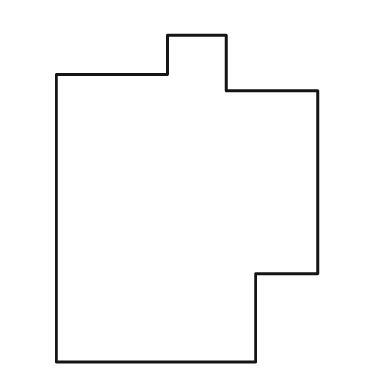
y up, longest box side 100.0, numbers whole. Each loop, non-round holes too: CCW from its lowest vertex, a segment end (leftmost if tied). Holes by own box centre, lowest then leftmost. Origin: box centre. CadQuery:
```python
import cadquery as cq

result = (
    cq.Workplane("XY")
    .moveTo(-40.0, -50.0)
    .lineTo(21.0, -50.0)
    .lineTo(21.0, -23.0)
    .lineTo(40.0, -23.0)
    .lineTo(40.0, 33.0)
    .lineTo(12.0, 33.0)
    .lineTo(12.0, 50.0)
    .lineTo(-6.0, 50.0)
    .lineTo(-6.0, 38.0)
    .lineTo(-40.0, 38.0)
    .close()
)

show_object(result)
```